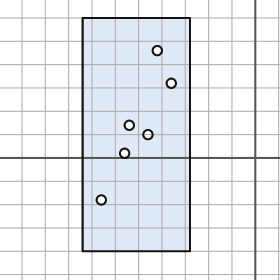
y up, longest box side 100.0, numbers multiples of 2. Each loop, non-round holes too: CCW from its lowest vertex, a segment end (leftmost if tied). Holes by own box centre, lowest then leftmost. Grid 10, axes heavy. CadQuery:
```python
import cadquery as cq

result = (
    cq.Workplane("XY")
    .moveTo(-74.0, -40.0)
    .lineTo(-28.0, -40.0)
    .lineTo(-28.0, 60.0)
    .lineTo(-74.0, 60.0)
    .close()
    .moveTo(-66.0, -18.0)
    .circle(2.0)
    .moveTo(-56.0, 2.0)
    .circle(2.0)
    .moveTo(-46.0, 10.0)
    .circle(2.0)
    .moveTo(-54.0, 14.0)
    .circle(2.0)
    .moveTo(-36.0, 32.0)
    .circle(2.0)
    .moveTo(-42.0, 46.0)
    .circle(2.0)
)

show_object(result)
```